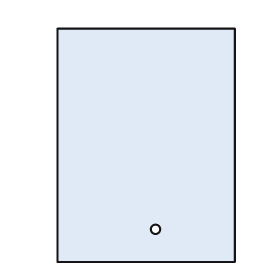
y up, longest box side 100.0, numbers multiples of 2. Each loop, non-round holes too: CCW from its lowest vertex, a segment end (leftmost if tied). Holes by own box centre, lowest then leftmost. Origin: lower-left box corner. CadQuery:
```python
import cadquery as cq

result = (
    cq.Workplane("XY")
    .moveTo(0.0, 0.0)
    .lineTo(76.0, 0.0)
    .lineTo(76.0, 100.0)
    .lineTo(0.0, 100.0)
    .close()
    .moveTo(42.0, 14.0)
    .circle(2.0)
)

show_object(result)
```